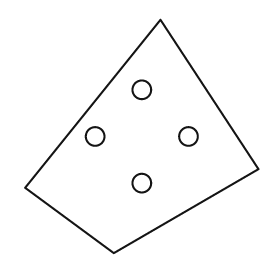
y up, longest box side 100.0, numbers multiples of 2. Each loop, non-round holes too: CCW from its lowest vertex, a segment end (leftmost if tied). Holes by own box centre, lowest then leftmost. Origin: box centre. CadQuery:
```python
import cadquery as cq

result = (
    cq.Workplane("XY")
    .moveTo(-12.0, -50.0)
    .lineTo(50.0, -14.0)
    .lineTo(8.0, 50.0)
    .lineTo(-50.0, -22.0)
    .close()
    .moveTo(0.0, -20.0)
    .circle(4.0)
    .moveTo(-20.0, 0.0)
    .circle(4.0)
    .moveTo(20.0, 0.0)
    .circle(4.0)
    .moveTo(0.0, 20.0)
    .circle(4.0)
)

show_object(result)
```